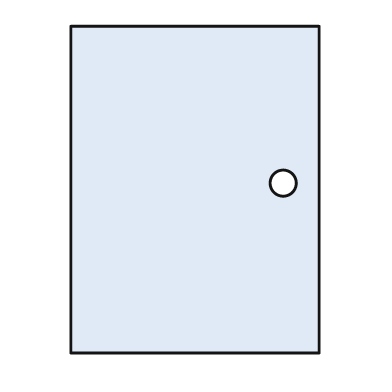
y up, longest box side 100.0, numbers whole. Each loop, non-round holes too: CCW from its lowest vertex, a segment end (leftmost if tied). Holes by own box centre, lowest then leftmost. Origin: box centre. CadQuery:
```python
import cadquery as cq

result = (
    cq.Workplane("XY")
    .moveTo(-38.0, -50.0)
    .lineTo(38.0, -50.0)
    .lineTo(38.0, 50.0)
    .lineTo(-38.0, 50.0)
    .close()
    .moveTo(27.0, 2.0)
    .circle(4.0)
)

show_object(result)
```